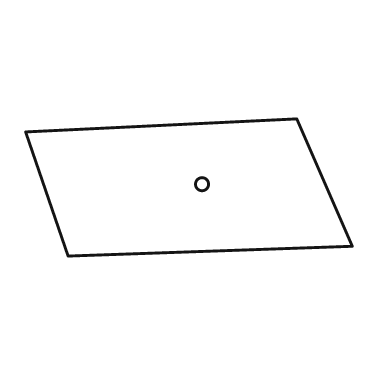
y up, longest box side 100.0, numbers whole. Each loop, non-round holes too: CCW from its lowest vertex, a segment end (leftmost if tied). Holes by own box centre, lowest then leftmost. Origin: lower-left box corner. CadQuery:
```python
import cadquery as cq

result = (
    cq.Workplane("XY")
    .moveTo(13.0, 0.0)
    .lineTo(100.0, 3.0)
    .lineTo(83.0, 42.0)
    .lineTo(0.0, 38.0)
    .close()
    .moveTo(54.0, 22.0)
    .circle(2.0)
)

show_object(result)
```